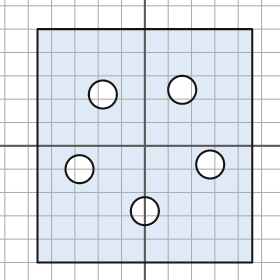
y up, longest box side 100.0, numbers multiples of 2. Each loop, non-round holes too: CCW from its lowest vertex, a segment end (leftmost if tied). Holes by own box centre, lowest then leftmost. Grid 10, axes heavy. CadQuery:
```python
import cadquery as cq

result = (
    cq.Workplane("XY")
    .moveTo(-46.0, -50.0)
    .lineTo(46.0, -50.0)
    .lineTo(46.0, 50.0)
    .lineTo(-46.0, 50.0)
    .close()
    .moveTo(0.0, -28.0)
    .circle(6.0)
    .moveTo(-28.0, -10.0)
    .circle(6.0)
    .moveTo(28.0, -8.0)
    .circle(6.0)
    .moveTo(-18.0, 22.0)
    .circle(6.0)
    .moveTo(16.0, 24.0)
    .circle(6.0)
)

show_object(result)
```